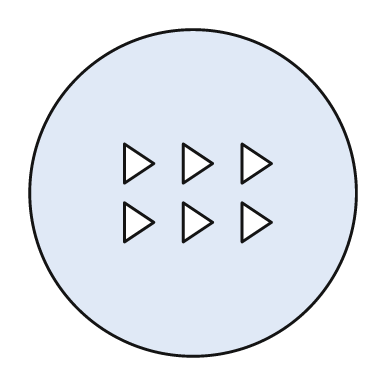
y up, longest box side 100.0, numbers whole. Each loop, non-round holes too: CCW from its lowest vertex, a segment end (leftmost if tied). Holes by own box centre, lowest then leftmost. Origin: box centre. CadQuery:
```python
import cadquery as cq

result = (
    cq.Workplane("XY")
    .moveTo(0.0, 0.0)
    .circle(50.0)
    .moveTo(-21.0, -15.0)
    .lineTo(-12.0, -9.0)
    .lineTo(-21.0, -3.0)
    .close()
    .moveTo(-3.0, -15.0)
    .lineTo(6.0, -9.0)
    .lineTo(-3.0, -3.0)
    .close()
    .moveTo(15.0, -15.0)
    .lineTo(24.0, -9.0)
    .lineTo(15.0, -3.0)
    .close()
    .moveTo(-21.0, 3.0)
    .lineTo(-12.0, 9.0)
    .lineTo(-21.0, 15.0)
    .close()
    .moveTo(-3.0, 3.0)
    .lineTo(6.0, 9.0)
    .lineTo(-3.0, 15.0)
    .close()
    .moveTo(15.0, 3.0)
    .lineTo(24.0, 9.0)
    .lineTo(15.0, 15.0)
    .close()
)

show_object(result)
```